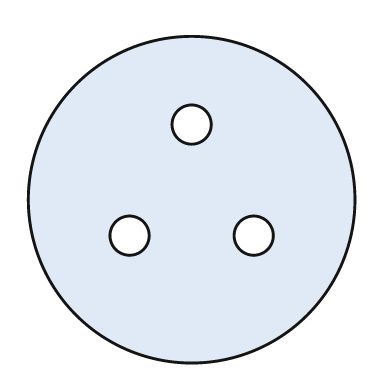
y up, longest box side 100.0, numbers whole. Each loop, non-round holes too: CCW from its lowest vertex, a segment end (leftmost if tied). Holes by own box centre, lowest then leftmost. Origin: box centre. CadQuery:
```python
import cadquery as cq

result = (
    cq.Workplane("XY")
    .moveTo(0.0, 0.0)
    .circle(50.0)
    .moveTo(-19.0, -11.0)
    .circle(6.0)
    .moveTo(19.0, -11.0)
    .circle(6.0)
    .moveTo(0.0, 23.0)
    .circle(6.0)
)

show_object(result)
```